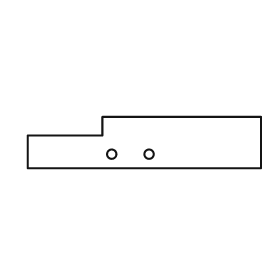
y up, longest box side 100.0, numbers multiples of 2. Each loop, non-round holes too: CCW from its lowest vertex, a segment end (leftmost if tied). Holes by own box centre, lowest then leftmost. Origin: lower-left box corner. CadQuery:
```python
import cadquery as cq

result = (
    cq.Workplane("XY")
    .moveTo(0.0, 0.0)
    .lineTo(100.0, 0.0)
    .lineTo(100.0, 22.0)
    .lineTo(32.0, 22.0)
    .lineTo(32.0, 14.0)
    .lineTo(0.0, 14.0)
    .close()
    .moveTo(36.0, 6.0)
    .circle(2.0)
    .moveTo(52.0, 6.0)
    .circle(2.0)
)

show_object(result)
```